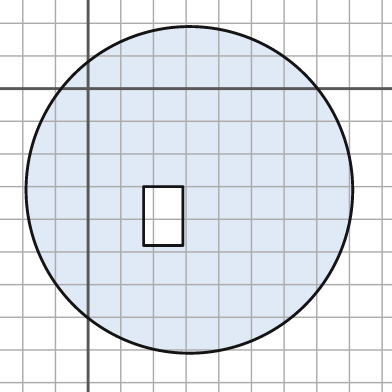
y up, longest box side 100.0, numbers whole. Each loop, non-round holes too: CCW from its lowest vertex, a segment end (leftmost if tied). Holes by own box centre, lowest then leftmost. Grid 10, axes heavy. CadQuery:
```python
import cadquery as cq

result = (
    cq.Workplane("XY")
    .moveTo(31.0, -31.0)
    .circle(50.0)
    .moveTo(17.0, -48.0)
    .lineTo(29.0, -48.0)
    .lineTo(29.0, -30.0)
    .lineTo(17.0, -30.0)
    .close()
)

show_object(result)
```